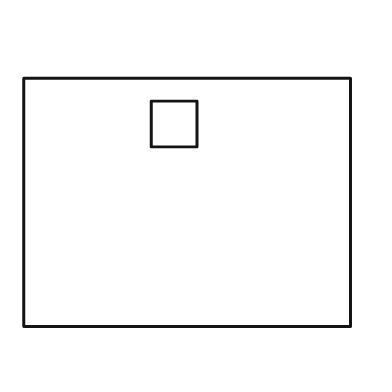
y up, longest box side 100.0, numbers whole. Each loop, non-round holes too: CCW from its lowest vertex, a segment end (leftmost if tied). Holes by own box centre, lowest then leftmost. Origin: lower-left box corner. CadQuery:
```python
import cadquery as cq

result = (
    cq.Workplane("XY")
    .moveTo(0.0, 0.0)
    .lineTo(100.0, 0.0)
    .lineTo(100.0, 76.0)
    .lineTo(0.0, 76.0)
    .close()
    .moveTo(39.0, 55.0)
    .lineTo(53.0, 55.0)
    .lineTo(53.0, 69.0)
    .lineTo(39.0, 69.0)
    .close()
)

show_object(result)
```